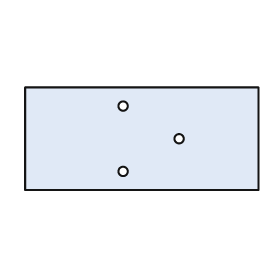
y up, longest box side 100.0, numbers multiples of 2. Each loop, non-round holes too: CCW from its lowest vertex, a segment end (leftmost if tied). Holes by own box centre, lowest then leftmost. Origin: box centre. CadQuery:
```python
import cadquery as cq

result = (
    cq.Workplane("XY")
    .moveTo(-50.0, -22.0)
    .lineTo(50.0, -22.0)
    .lineTo(50.0, 22.0)
    .lineTo(-50.0, 22.0)
    .close()
    .moveTo(-8.0, -14.0)
    .circle(2.0)
    .moveTo(16.0, 0.0)
    .circle(2.0)
    .moveTo(-8.0, 14.0)
    .circle(2.0)
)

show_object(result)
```